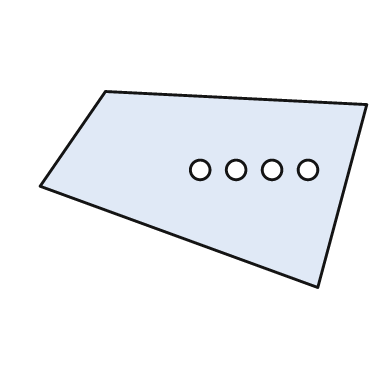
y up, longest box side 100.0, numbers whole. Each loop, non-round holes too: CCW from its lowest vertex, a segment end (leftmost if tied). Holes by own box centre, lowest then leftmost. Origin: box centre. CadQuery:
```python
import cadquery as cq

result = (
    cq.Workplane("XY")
    .moveTo(35.0, -30.0)
    .lineTo(50.0, 26.0)
    .lineTo(-30.0, 30.0)
    .lineTo(-50.0, 1.0)
    .close()
    .moveTo(-1.0, 6.0)
    .circle(3.0)
    .moveTo(10.0, 6.0)
    .circle(3.0)
    .moveTo(21.0, 6.0)
    .circle(3.0)
    .moveTo(32.0, 6.0)
    .circle(3.0)
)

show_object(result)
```